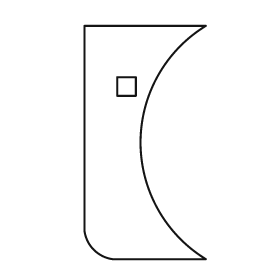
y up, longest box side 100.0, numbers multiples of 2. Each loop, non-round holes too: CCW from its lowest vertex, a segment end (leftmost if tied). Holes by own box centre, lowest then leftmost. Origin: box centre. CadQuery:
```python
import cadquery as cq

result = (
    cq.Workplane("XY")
    .moveTo(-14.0, -50.0)
    .lineTo(26.0, -50.0)
    .threePointArc((-2.0, 0.0), (26.0, 50.0))
    .lineTo(-26.0, 50.0)
    .lineTo(-26.0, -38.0)
    .threePointArc((-22.0, -46.0), (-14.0, -50.0))
    .close()
    .moveTo(-12.0, 20.0)
    .lineTo(-4.0, 20.0)
    .lineTo(-4.0, 28.0)
    .lineTo(-12.0, 28.0)
    .close()
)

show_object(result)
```